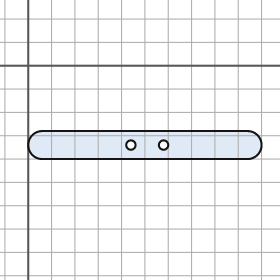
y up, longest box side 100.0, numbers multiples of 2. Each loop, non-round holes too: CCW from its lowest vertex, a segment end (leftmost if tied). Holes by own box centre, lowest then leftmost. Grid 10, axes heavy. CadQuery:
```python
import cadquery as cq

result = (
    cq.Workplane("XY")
    .moveTo(6.0, -40.0)
    .lineTo(94.0, -40.0)
    .threePointArc((100.0, -34.0), (94.0, -28.0))
    .lineTo(6.0, -28.0)
    .threePointArc((0.0, -34.0), (6.0, -40.0))
    .close()
    .moveTo(44.0, -34.0)
    .circle(2.0)
    .moveTo(58.0, -34.0)
    .circle(2.0)
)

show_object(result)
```